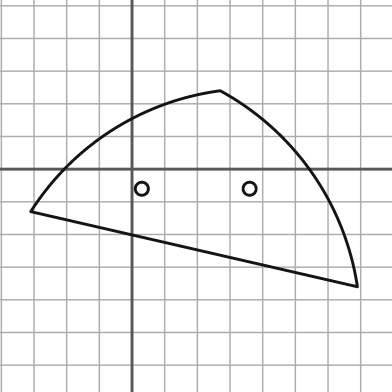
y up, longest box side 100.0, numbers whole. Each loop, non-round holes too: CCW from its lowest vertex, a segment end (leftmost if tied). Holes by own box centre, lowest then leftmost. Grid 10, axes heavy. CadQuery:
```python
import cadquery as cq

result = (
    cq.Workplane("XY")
    .moveTo(69.0, -36.0)
    .threePointArc((55.0, -1.0), (27.0, 24.0))
    .threePointArc((-6.0, 12.0), (-31.0, -13.0))
    .close()
    .moveTo(3.0, -6.0)
    .circle(2.0)
    .moveTo(36.0, -6.0)
    .circle(2.0)
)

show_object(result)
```